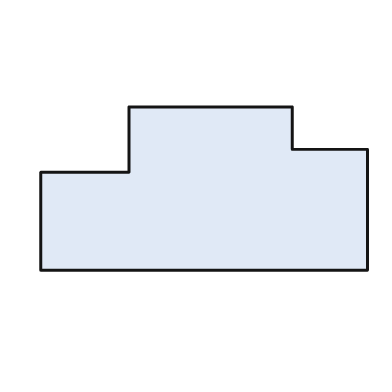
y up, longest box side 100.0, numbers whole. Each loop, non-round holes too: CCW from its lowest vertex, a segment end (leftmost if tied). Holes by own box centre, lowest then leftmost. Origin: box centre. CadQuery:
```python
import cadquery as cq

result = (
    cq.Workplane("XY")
    .moveTo(-50.0, -25.0)
    .lineTo(50.0, -25.0)
    .lineTo(50.0, 12.0)
    .lineTo(27.0, 12.0)
    .lineTo(27.0, 25.0)
    .lineTo(-23.0, 25.0)
    .lineTo(-23.0, 5.0)
    .lineTo(-50.0, 5.0)
    .close()
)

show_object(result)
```